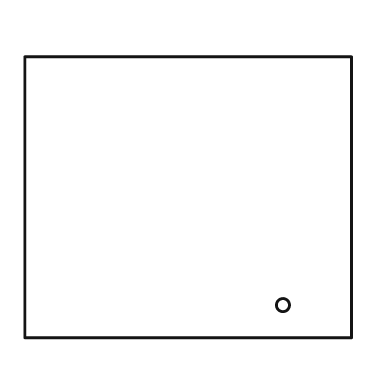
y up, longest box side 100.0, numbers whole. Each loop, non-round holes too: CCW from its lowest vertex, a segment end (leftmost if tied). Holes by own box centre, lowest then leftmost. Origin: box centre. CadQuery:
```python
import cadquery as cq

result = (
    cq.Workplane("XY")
    .moveTo(-50.0, -43.0)
    .lineTo(50.0, -43.0)
    .lineTo(50.0, 43.0)
    .lineTo(-50.0, 43.0)
    .close()
    .moveTo(29.0, -33.0)
    .circle(2.0)
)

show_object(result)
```